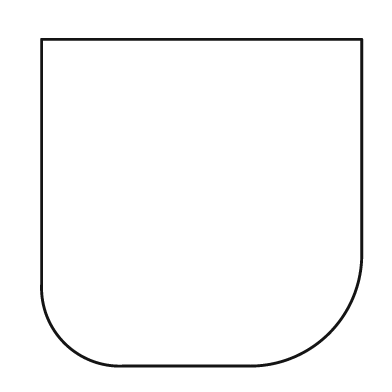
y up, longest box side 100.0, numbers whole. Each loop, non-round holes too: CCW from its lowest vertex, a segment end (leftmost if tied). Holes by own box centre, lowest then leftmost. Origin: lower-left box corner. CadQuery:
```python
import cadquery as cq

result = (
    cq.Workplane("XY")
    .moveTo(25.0, 0.0)
    .lineTo(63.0, 0.0)
    .threePointArc((88.0, 10.0), (98.0, 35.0))
    .lineTo(98.0, 100.0)
    .lineTo(0.0, 100.0)
    .lineTo(0.0, 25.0)
    .threePointArc((7.0, 7.0), (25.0, 0.0))
    .close()
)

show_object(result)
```